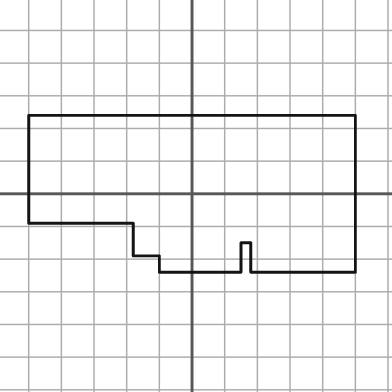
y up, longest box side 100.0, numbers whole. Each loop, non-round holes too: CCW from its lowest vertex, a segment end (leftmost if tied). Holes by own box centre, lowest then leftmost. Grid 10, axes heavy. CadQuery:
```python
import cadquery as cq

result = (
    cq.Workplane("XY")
    .moveTo(-10.0, -24.0)
    .lineTo(15.0, -24.0)
    .lineTo(15.0, -15.0)
    .lineTo(18.0, -15.0)
    .lineTo(18.0, -24.0)
    .lineTo(50.0, -24.0)
    .lineTo(50.0, 24.0)
    .lineTo(-50.0, 24.0)
    .lineTo(-50.0, -9.0)
    .lineTo(-18.0, -9.0)
    .lineTo(-18.0, -19.0)
    .lineTo(-10.0, -19.0)
    .close()
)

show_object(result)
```